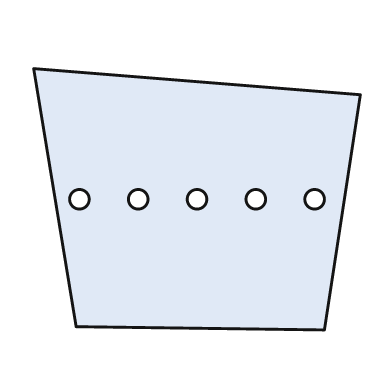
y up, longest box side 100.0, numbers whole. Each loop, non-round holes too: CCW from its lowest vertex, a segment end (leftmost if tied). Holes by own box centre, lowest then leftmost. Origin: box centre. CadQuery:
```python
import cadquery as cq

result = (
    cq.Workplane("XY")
    .moveTo(39.0, -40.0)
    .lineTo(50.0, 32.0)
    .lineTo(-50.0, 40.0)
    .lineTo(-37.0, -39.0)
    .close()
    .moveTo(-36.0, 0.0)
    .circle(3.0)
    .moveTo(-18.0, 0.0)
    .circle(3.0)
    .moveTo(0.0, 0.0)
    .circle(3.0)
    .moveTo(18.0, 0.0)
    .circle(3.0)
    .moveTo(36.0, 0.0)
    .circle(3.0)
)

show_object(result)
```